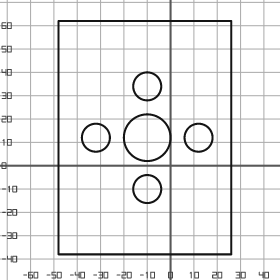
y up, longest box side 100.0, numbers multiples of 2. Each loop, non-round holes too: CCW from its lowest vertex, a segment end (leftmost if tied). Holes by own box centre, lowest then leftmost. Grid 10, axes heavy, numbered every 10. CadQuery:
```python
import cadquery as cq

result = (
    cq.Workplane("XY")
    .moveTo(-48.0, -38.0)
    .lineTo(26.0, -38.0)
    .lineTo(26.0, 62.0)
    .lineTo(-48.0, 62.0)
    .close()
    .moveTo(-10.0, -10.0)
    .circle(6.0)
    .moveTo(-32.0, 12.0)
    .circle(6.0)
    .moveTo(-10.0, 12.0)
    .circle(10.0)
    .moveTo(12.0, 12.0)
    .circle(6.0)
    .moveTo(-10.0, 34.0)
    .circle(6.0)
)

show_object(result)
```